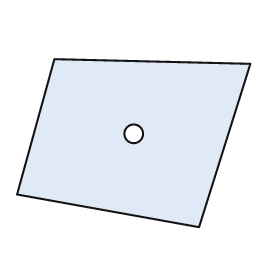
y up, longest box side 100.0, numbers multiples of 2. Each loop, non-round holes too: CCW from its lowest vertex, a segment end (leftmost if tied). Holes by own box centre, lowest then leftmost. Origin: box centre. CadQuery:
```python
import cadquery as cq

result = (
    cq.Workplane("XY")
    .moveTo(28.0, -36.0)
    .lineTo(50.0, 34.0)
    .lineTo(-34.0, 36.0)
    .lineTo(-50.0, -22.0)
    .close()
    .moveTo(0.0, 4.0)
    .circle(4.0)
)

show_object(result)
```